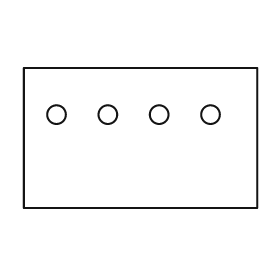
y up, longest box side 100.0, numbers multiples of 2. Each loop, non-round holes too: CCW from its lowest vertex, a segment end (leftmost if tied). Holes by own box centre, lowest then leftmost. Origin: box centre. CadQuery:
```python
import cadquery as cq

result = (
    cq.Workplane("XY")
    .moveTo(-50.0, -30.0)
    .lineTo(50.0, -30.0)
    .lineTo(50.0, 30.0)
    .lineTo(-50.0, 30.0)
    .close()
    .moveTo(-36.0, 10.0)
    .circle(4.0)
    .moveTo(-14.0, 10.0)
    .circle(4.0)
    .moveTo(8.0, 10.0)
    .circle(4.0)
    .moveTo(30.0, 10.0)
    .circle(4.0)
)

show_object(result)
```